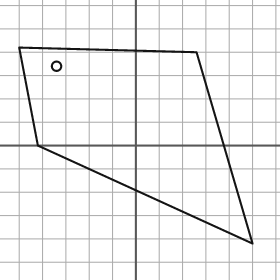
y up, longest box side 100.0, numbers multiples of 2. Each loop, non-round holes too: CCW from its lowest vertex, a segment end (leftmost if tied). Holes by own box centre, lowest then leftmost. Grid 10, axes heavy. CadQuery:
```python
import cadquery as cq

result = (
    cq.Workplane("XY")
    .moveTo(50.0, -42.0)
    .lineTo(26.0, 40.0)
    .lineTo(-50.0, 42.0)
    .lineTo(-42.0, 0.0)
    .close()
    .moveTo(-34.0, 34.0)
    .circle(2.0)
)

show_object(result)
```